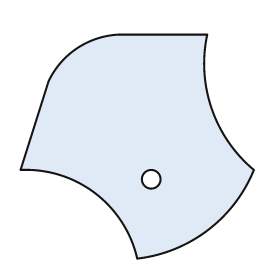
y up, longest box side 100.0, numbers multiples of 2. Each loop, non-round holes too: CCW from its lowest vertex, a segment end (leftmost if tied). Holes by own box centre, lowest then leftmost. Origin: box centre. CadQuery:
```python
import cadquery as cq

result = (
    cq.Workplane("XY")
    .moveTo(0.0, -48.0)
    .threePointArc((30.0, -36.0), (50.0, -10.0))
    .threePointArc((32.0, 16.0), (30.0, 48.0))
    .lineTo(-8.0, 48.0)
    .threePointArc((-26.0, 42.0), (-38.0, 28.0))
    .lineTo(-50.0, -10.0)
    .threePointArc((-18.0, -20.0), (0.0, -48.0))
    .close()
    .moveTo(6.0, -14.0)
    .circle(4.0)
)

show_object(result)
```